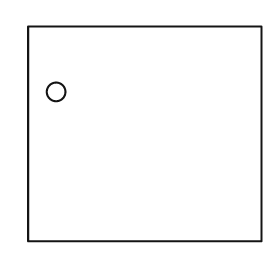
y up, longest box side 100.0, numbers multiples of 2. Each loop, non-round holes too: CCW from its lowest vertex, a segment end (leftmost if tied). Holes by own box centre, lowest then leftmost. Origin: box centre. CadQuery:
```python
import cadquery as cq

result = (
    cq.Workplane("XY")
    .moveTo(-50.0, -46.0)
    .lineTo(50.0, -46.0)
    .lineTo(50.0, 46.0)
    .lineTo(-50.0, 46.0)
    .close()
    .moveTo(-38.0, 18.0)
    .circle(4.0)
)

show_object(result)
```